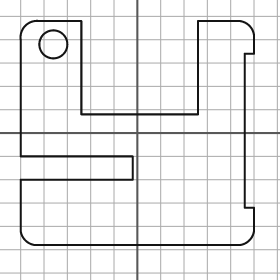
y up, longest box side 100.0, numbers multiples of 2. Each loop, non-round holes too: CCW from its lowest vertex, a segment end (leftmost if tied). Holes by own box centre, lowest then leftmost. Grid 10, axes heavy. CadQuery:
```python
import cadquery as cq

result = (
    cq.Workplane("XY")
    .moveTo(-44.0, -48.0)
    .lineTo(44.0, -48.0)
    .threePointArc((48.0, -46.0), (50.0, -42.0))
    .lineTo(50.0, -32.0)
    .lineTo(46.0, -32.0)
    .lineTo(46.0, 34.0)
    .lineTo(50.0, 34.0)
    .lineTo(50.0, 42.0)
    .threePointArc((48.0, 46.0), (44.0, 48.0))
    .lineTo(26.0, 48.0)
    .lineTo(26.0, 8.0)
    .lineTo(-24.0, 8.0)
    .lineTo(-24.0, 48.0)
    .lineTo(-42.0, 48.0)
    .threePointArc((-48.0, 46.0), (-50.0, 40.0))
    .lineTo(-50.0, -10.0)
    .lineTo(-2.0, -10.0)
    .lineTo(-2.0, -20.0)
    .lineTo(-50.0, -20.0)
    .lineTo(-50.0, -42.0)
    .threePointArc((-48.0, -46.0), (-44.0, -48.0))
    .close()
    .moveTo(-36.0, 38.0)
    .circle(6.0)
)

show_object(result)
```